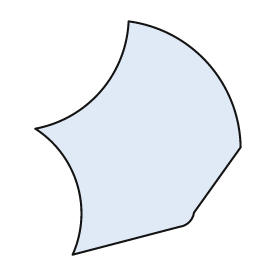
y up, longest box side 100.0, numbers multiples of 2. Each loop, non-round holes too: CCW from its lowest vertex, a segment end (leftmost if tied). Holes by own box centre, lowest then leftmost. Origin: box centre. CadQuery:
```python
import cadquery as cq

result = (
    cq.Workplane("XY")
    .moveTo(-28.0, -50.0)
    .lineTo(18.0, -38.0)
    .threePointArc((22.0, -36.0), (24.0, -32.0))
    .lineTo(44.0, -4.0)
    .threePointArc((30.0, 32.0), (-4.0, 50.0))
    .threePointArc((-16.0, 20.0), (-44.0, 4.0))
    .threePointArc((-26.0, -20.0), (-28.0, -50.0))
    .close()
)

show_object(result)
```